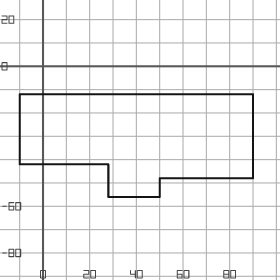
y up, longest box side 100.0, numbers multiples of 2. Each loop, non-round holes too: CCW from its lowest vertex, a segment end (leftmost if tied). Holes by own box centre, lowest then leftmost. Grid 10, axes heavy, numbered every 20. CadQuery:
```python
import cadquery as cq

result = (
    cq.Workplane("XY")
    .moveTo(28.0, -56.0)
    .lineTo(50.0, -56.0)
    .lineTo(50.0, -48.0)
    .lineTo(90.0, -48.0)
    .lineTo(90.0, -12.0)
    .lineTo(-10.0, -12.0)
    .lineTo(-10.0, -42.0)
    .lineTo(28.0, -42.0)
    .close()
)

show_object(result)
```